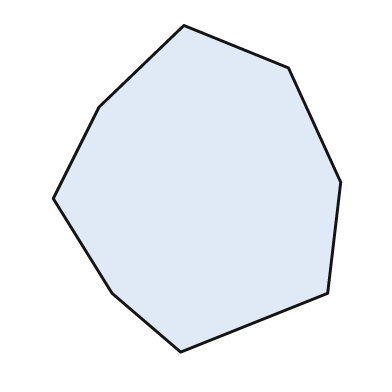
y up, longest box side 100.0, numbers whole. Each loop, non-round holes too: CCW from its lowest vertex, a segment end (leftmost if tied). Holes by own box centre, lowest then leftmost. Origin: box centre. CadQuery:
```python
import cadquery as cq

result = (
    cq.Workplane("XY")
    .moveTo(-5.0, -50.0)
    .lineTo(40.0, -32.0)
    .lineTo(44.0, 2.0)
    .lineTo(28.0, 37.0)
    .lineTo(-4.0, 50.0)
    .lineTo(-30.0, 25.0)
    .lineTo(-44.0, -3.0)
    .lineTo(-26.0, -32.0)
    .close()
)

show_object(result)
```